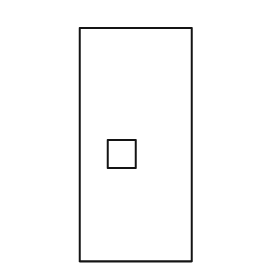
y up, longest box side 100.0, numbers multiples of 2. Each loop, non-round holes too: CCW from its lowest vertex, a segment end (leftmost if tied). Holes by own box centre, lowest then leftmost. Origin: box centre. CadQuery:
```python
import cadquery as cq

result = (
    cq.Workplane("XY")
    .moveTo(-24.0, -50.0)
    .lineTo(24.0, -50.0)
    .lineTo(24.0, 50.0)
    .lineTo(-24.0, 50.0)
    .close()
    .moveTo(-12.0, -10.0)
    .lineTo(0.0, -10.0)
    .lineTo(0.0, 2.0)
    .lineTo(-12.0, 2.0)
    .close()
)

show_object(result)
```